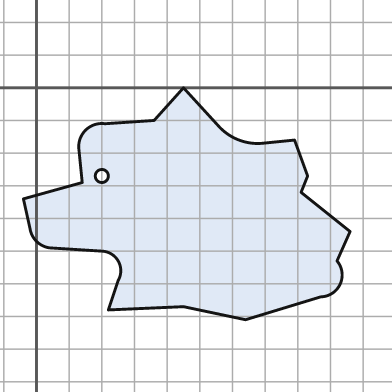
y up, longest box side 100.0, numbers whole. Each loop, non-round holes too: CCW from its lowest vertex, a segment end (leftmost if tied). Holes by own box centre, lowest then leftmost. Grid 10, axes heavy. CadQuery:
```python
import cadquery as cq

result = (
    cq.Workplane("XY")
    .moveTo(64.0, -71.0)
    .lineTo(87.0, -64.0)
    .threePointArc((93.0, -60.0), (92.0, -53.0))
    .lineTo(96.0, -44.0)
    .lineTo(81.0, -32.0)
    .lineTo(83.0, -27.0)
    .lineTo(79.0, -16.0)
    .lineTo(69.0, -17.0)
    .threePointArc((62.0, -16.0), (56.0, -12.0))
    .lineTo(45.0, 0.0)
    .lineTo(36.0, -10.0)
    .lineTo(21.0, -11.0)
    .threePointArc((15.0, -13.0), (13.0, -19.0))
    .lineTo(14.0, -29.0)
    .lineTo(-4.0, -34.0)
    .lineTo(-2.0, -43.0)
    .threePointArc((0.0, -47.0), (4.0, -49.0))
    .lineTo(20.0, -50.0)
    .threePointArc((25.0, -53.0), (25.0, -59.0))
    .lineTo(22.0, -68.0)
    .lineTo(45.0, -67.0)
    .close()
    .moveTo(20.0, -27.0)
    .circle(2.0)
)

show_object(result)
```